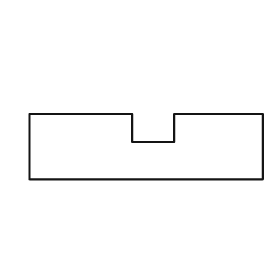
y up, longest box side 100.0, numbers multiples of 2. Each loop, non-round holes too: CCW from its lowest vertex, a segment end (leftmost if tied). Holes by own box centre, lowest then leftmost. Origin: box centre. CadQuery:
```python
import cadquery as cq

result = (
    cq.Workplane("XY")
    .moveTo(-50.0, -14.0)
    .lineTo(50.0, -14.0)
    .lineTo(50.0, 14.0)
    .lineTo(12.0, 14.0)
    .lineTo(12.0, 2.0)
    .lineTo(-6.0, 2.0)
    .lineTo(-6.0, 14.0)
    .lineTo(-50.0, 14.0)
    .close()
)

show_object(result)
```